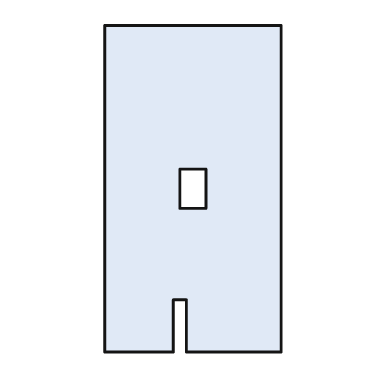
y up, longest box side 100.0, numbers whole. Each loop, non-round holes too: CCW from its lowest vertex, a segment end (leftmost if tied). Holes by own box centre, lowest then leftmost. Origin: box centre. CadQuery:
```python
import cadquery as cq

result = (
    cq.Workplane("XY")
    .moveTo(-27.0, -50.0)
    .lineTo(-6.0, -50.0)
    .lineTo(-6.0, -34.0)
    .lineTo(-2.0, -34.0)
    .lineTo(-2.0, -50.0)
    .lineTo(27.0, -50.0)
    .lineTo(27.0, 50.0)
    .lineTo(-27.0, 50.0)
    .close()
    .moveTo(-4.0, -6.0)
    .lineTo(4.0, -6.0)
    .lineTo(4.0, 6.0)
    .lineTo(-4.0, 6.0)
    .close()
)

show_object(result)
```